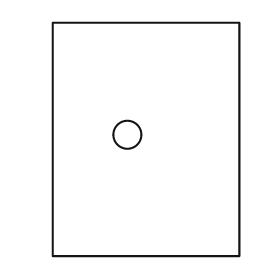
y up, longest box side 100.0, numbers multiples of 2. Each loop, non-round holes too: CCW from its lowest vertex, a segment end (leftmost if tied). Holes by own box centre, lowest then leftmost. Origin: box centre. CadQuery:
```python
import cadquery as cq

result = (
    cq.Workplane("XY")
    .moveTo(-40.0, -50.0)
    .lineTo(40.0, -50.0)
    .lineTo(40.0, 50.0)
    .lineTo(-40.0, 50.0)
    .close()
    .moveTo(-8.0, 2.0)
    .circle(6.0)
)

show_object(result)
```